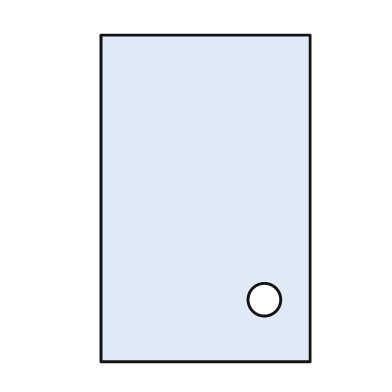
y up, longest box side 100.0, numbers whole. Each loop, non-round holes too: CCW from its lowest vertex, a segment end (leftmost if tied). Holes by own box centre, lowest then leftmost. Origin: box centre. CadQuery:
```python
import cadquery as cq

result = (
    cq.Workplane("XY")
    .moveTo(-32.0, -50.0)
    .lineTo(32.0, -50.0)
    .lineTo(32.0, 50.0)
    .lineTo(-32.0, 50.0)
    .close()
    .moveTo(18.0, -31.0)
    .circle(5.0)
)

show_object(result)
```